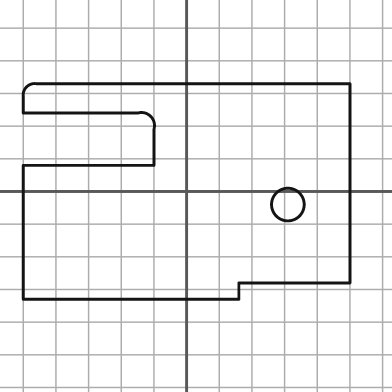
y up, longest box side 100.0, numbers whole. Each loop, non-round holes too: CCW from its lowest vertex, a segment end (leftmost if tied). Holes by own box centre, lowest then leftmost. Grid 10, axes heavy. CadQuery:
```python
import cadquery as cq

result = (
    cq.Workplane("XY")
    .moveTo(-50.0, -33.0)
    .lineTo(16.0, -33.0)
    .lineTo(16.0, -28.0)
    .lineTo(50.0, -28.0)
    .lineTo(50.0, 33.0)
    .lineTo(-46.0, 33.0)
    .threePointArc((-49.0, 32.0), (-50.0, 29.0))
    .lineTo(-50.0, 24.0)
    .lineTo(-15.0, 24.0)
    .threePointArc((-11.0, 23.0), (-10.0, 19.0))
    .lineTo(-10.0, 8.0)
    .lineTo(-50.0, 8.0)
    .close()
    .moveTo(31.0, -4.0)
    .circle(5.0)
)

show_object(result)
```